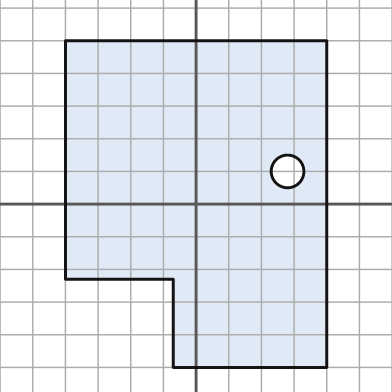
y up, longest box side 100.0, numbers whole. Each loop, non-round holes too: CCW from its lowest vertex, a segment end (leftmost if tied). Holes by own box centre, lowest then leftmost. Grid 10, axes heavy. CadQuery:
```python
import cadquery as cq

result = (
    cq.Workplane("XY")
    .moveTo(-7.0, -50.0)
    .lineTo(40.0, -50.0)
    .lineTo(40.0, 50.0)
    .lineTo(-40.0, 50.0)
    .lineTo(-40.0, -23.0)
    .lineTo(-7.0, -23.0)
    .close()
    .moveTo(28.0, 10.0)
    .circle(5.0)
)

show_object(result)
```